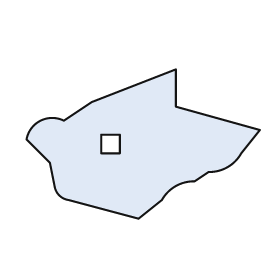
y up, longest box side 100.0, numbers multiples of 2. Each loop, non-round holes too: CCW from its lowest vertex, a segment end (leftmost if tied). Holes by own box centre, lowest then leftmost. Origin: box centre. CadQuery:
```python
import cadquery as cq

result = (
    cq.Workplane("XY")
    .moveTo(-2.0, -32.0)
    .lineTo(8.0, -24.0)
    .threePointArc((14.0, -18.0), (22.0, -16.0))
    .lineTo(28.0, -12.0)
    .threePointArc((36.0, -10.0), (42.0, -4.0))
    .lineTo(50.0, 6.0)
    .lineTo(14.0, 16.0)
    .lineTo(14.0, 32.0)
    .lineTo(-22.0, 18.0)
    .lineTo(-34.0, 10.0)
    .threePointArc((-44.0, 10.0), (-50.0, 2.0))
    .lineTo(-40.0, -8.0)
    .lineTo(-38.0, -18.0)
    .threePointArc((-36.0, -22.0), (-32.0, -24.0))
    .close()
    .moveTo(-18.0, -4.0)
    .lineTo(-10.0, -4.0)
    .lineTo(-10.0, 4.0)
    .lineTo(-18.0, 4.0)
    .close()
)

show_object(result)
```